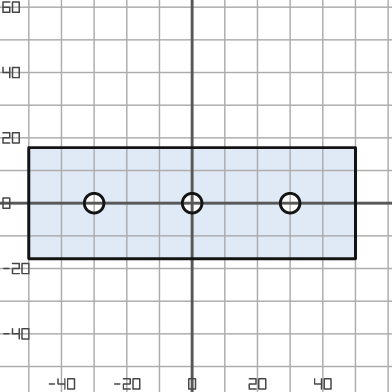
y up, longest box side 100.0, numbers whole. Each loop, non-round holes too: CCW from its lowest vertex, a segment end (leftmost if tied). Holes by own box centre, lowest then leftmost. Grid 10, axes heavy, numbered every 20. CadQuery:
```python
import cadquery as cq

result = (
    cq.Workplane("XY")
    .moveTo(-50.0, -17.0)
    .lineTo(50.0, -17.0)
    .lineTo(50.0, 17.0)
    .lineTo(-50.0, 17.0)
    .close()
    .moveTo(-30.0, 0.0)
    .circle(3.0)
    .moveTo(0.0, 0.0)
    .circle(3.0)
    .moveTo(30.0, 0.0)
    .circle(3.0)
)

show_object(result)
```